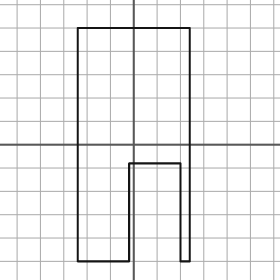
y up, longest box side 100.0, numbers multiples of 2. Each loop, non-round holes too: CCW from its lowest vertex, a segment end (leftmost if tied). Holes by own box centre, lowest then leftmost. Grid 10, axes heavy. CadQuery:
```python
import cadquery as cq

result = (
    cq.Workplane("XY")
    .moveTo(-24.0, -50.0)
    .lineTo(-2.0, -50.0)
    .lineTo(-2.0, -8.0)
    .lineTo(20.0, -8.0)
    .lineTo(20.0, -50.0)
    .lineTo(24.0, -50.0)
    .lineTo(24.0, 50.0)
    .lineTo(-24.0, 50.0)
    .close()
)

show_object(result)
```